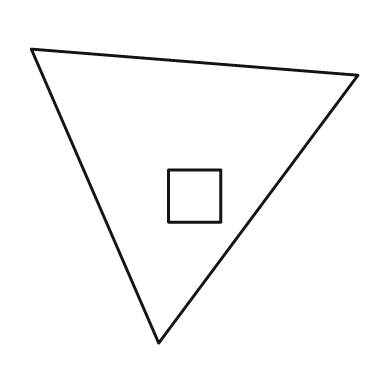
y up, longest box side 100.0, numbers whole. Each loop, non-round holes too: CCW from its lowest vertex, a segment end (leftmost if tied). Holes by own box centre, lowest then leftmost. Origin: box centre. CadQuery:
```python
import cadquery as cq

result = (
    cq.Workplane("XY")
    .moveTo(-11.0, -45.0)
    .lineTo(50.0, 37.0)
    .lineTo(-50.0, 45.0)
    .close()
    .moveTo(-8.0, -8.0)
    .lineTo(8.0, -8.0)
    .lineTo(8.0, 8.0)
    .lineTo(-8.0, 8.0)
    .close()
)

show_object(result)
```